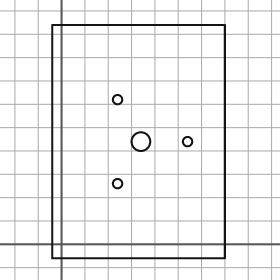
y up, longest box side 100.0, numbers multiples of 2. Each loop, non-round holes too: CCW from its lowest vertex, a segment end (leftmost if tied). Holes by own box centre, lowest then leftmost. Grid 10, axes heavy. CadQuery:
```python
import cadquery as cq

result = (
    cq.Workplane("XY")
    .moveTo(-4.0, -6.0)
    .lineTo(70.0, -6.0)
    .lineTo(70.0, 94.0)
    .lineTo(-4.0, 94.0)
    .close()
    .moveTo(24.0, 26.0)
    .circle(2.0)
    .moveTo(34.0, 44.0)
    .circle(4.0)
    .moveTo(54.0, 44.0)
    .circle(2.0)
    .moveTo(24.0, 62.0)
    .circle(2.0)
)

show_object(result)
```